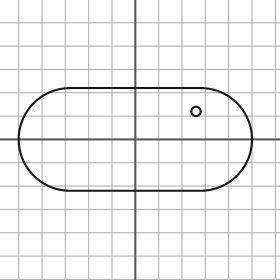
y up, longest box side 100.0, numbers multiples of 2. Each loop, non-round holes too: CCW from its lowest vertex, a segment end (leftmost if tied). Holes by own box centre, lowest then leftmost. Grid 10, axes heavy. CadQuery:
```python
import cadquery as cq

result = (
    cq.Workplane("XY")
    .moveTo(-28.0, -22.0)
    .lineTo(28.0, -22.0)
    .threePointArc((50.0, 0.0), (28.0, 22.0))
    .lineTo(-28.0, 22.0)
    .threePointArc((-50.0, 0.0), (-28.0, -22.0))
    .close()
    .moveTo(26.0, 12.0)
    .circle(2.0)
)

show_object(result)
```